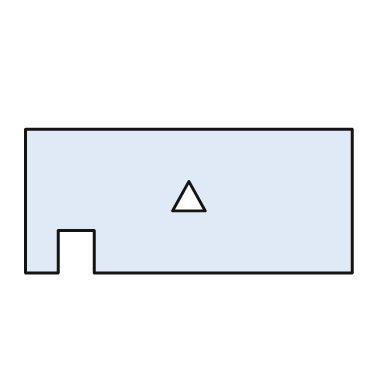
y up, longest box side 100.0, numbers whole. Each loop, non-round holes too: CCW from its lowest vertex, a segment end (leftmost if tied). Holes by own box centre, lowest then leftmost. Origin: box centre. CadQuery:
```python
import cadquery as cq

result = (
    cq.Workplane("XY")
    .moveTo(-50.0, -22.0)
    .lineTo(-40.0, -22.0)
    .lineTo(-40.0, -9.0)
    .lineTo(-29.0, -9.0)
    .lineTo(-29.0, -22.0)
    .lineTo(50.0, -22.0)
    .lineTo(50.0, 22.0)
    .lineTo(-50.0, 22.0)
    .close()
    .moveTo(-5.0, -3.0)
    .lineTo(5.0, -3.0)
    .lineTo(0.0, 6.0)
    .close()
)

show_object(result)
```